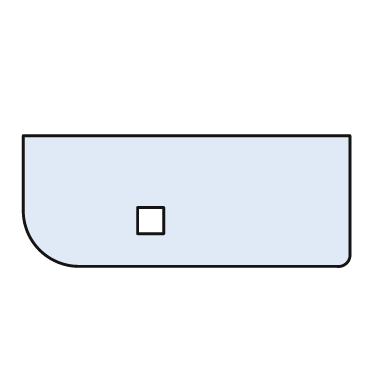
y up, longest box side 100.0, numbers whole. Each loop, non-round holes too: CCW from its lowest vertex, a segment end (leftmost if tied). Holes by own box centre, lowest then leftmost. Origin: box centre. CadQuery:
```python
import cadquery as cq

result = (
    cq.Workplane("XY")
    .moveTo(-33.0, -20.0)
    .lineTo(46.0, -20.0)
    .threePointArc((49.0, -19.0), (50.0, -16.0))
    .lineTo(50.0, 20.0)
    .lineTo(-50.0, 20.0)
    .lineTo(-50.0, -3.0)
    .threePointArc((-45.0, -15.0), (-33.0, -20.0))
    .close()
    .moveTo(-15.0, -10.0)
    .lineTo(-7.0, -10.0)
    .lineTo(-7.0, -2.0)
    .lineTo(-15.0, -2.0)
    .close()
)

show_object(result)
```